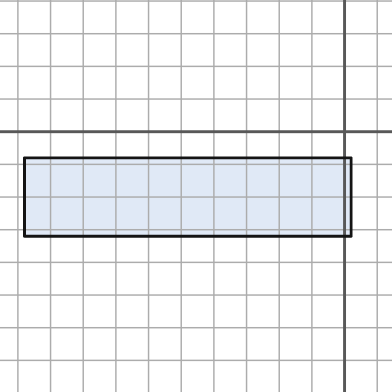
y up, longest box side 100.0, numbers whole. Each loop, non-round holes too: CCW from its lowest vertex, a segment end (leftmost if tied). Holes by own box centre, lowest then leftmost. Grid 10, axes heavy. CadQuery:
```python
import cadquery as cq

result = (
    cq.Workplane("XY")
    .moveTo(-98.0, -32.0)
    .lineTo(2.0, -32.0)
    .lineTo(2.0, -8.0)
    .lineTo(-98.0, -8.0)
    .close()
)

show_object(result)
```